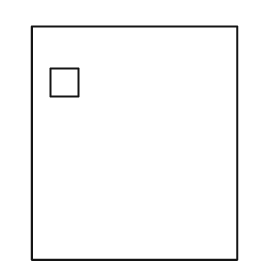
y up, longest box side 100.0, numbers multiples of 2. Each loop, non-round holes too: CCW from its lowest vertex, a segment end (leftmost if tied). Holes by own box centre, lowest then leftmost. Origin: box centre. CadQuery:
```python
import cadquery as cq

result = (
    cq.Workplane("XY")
    .moveTo(-44.0, -50.0)
    .lineTo(44.0, -50.0)
    .lineTo(44.0, 50.0)
    .lineTo(-44.0, 50.0)
    .close()
    .moveTo(-36.0, 20.0)
    .lineTo(-24.0, 20.0)
    .lineTo(-24.0, 32.0)
    .lineTo(-36.0, 32.0)
    .close()
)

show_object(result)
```